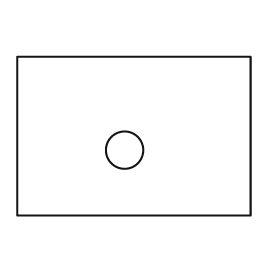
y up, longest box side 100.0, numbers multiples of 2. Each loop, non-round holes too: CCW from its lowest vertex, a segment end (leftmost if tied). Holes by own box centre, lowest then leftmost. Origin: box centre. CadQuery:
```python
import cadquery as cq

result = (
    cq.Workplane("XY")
    .moveTo(-50.0, -34.0)
    .lineTo(50.0, -34.0)
    .lineTo(50.0, 34.0)
    .lineTo(-50.0, 34.0)
    .close()
    .moveTo(-4.0, -6.0)
    .circle(8.0)
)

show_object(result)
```